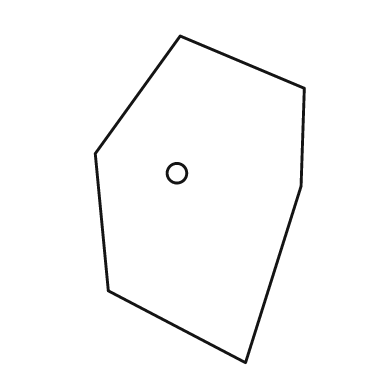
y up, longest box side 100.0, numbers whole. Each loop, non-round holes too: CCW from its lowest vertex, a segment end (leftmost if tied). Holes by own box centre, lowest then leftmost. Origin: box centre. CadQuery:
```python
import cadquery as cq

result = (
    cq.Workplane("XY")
    .moveTo(14.0, -50.0)
    .lineTo(31.0, 4.0)
    .lineTo(32.0, 34.0)
    .lineTo(-6.0, 50.0)
    .lineTo(-32.0, 14.0)
    .lineTo(-28.0, -28.0)
    .close()
    .moveTo(-7.0, 8.0)
    .circle(3.0)
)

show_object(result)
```